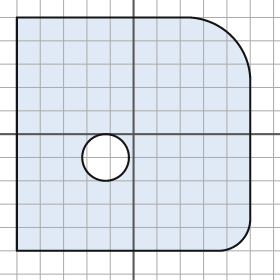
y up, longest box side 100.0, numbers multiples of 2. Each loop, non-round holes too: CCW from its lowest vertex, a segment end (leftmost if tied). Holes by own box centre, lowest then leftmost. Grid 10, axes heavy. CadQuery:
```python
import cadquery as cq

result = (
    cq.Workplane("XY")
    .moveTo(-50.0, -50.0)
    .lineTo(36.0, -50.0)
    .threePointArc((46.0, -46.0), (50.0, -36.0))
    .lineTo(50.0, 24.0)
    .threePointArc((42.0, 42.0), (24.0, 50.0))
    .lineTo(-50.0, 50.0)
    .close()
    .moveTo(-12.0, -10.0)
    .circle(10.0)
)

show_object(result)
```